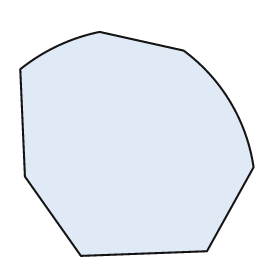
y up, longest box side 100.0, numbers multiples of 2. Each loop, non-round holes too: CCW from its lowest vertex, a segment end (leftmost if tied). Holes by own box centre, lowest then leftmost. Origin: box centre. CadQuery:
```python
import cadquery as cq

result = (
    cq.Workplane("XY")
    .moveTo(-24.0, -48.0)
    .lineTo(30.0, -46.0)
    .lineTo(50.0, -10.0)
    .threePointArc((40.0, 18.0), (20.0, 40.0))
    .lineTo(-16.0, 48.0)
    .threePointArc((-34.0, 42.0), (-50.0, 32.0))
    .lineTo(-48.0, -14.0)
    .close()
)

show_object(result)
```